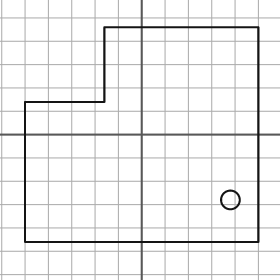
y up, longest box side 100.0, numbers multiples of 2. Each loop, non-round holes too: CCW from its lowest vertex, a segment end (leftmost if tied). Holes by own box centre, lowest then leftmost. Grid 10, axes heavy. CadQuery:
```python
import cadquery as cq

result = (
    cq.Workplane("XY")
    .moveTo(-50.0, -46.0)
    .lineTo(50.0, -46.0)
    .lineTo(50.0, 46.0)
    .lineTo(-16.0, 46.0)
    .lineTo(-16.0, 14.0)
    .lineTo(-50.0, 14.0)
    .close()
    .moveTo(38.0, -28.0)
    .circle(4.0)
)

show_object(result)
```